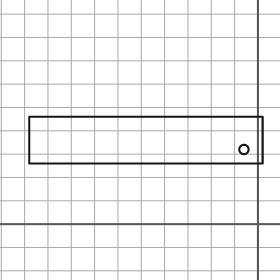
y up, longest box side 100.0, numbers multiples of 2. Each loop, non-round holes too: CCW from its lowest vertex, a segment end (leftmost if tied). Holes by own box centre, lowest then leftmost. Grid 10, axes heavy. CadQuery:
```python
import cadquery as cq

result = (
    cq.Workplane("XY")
    .moveTo(-98.0, 26.0)
    .lineTo(2.0, 26.0)
    .lineTo(2.0, 46.0)
    .lineTo(-98.0, 46.0)
    .close()
    .moveTo(-6.0, 32.0)
    .circle(2.0)
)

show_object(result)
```